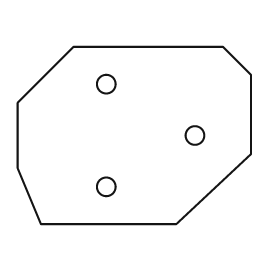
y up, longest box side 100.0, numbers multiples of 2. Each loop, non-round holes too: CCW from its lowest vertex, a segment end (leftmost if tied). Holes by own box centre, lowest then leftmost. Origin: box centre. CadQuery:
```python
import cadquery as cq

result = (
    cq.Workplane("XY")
    .moveTo(-40.0, -38.0)
    .lineTo(18.0, -38.0)
    .lineTo(50.0, -8.0)
    .lineTo(50.0, 26.0)
    .lineTo(38.0, 38.0)
    .lineTo(-26.0, 38.0)
    .lineTo(-50.0, 14.0)
    .lineTo(-50.0, -14.0)
    .close()
    .moveTo(-12.0, -22.0)
    .circle(4.0)
    .moveTo(26.0, 0.0)
    .circle(4.0)
    .moveTo(-12.0, 22.0)
    .circle(4.0)
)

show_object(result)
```